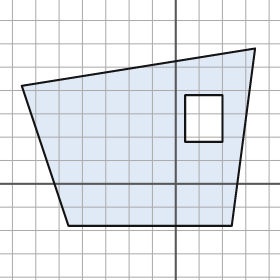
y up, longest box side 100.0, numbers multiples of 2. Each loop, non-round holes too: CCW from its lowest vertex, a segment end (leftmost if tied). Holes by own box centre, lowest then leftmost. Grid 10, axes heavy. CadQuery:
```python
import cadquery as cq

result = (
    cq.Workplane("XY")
    .moveTo(-46.0, -18.0)
    .lineTo(24.0, -18.0)
    .lineTo(34.0, 58.0)
    .lineTo(-66.0, 42.0)
    .close()
    .moveTo(4.0, 18.0)
    .lineTo(20.0, 18.0)
    .lineTo(20.0, 38.0)
    .lineTo(4.0, 38.0)
    .close()
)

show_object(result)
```